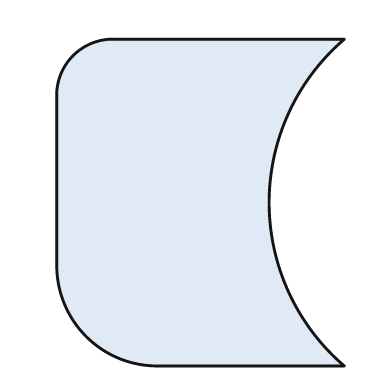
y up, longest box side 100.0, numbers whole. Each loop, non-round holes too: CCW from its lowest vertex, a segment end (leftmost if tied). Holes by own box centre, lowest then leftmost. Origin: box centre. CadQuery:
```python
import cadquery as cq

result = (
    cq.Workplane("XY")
    .moveTo(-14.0, -50.0)
    .lineTo(44.0, -50.0)
    .threePointArc((21.0, 0.0), (44.0, 50.0))
    .lineTo(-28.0, 50.0)
    .threePointArc((-39.0, 45.0), (-44.0, 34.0))
    .lineTo(-44.0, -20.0)
    .threePointArc((-35.0, -41.0), (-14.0, -50.0))
    .close()
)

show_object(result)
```